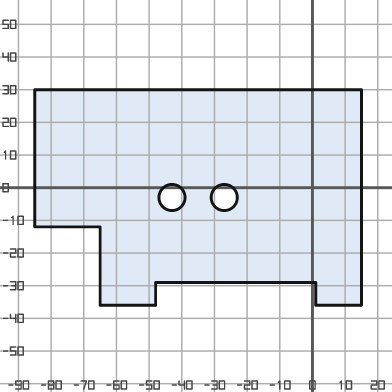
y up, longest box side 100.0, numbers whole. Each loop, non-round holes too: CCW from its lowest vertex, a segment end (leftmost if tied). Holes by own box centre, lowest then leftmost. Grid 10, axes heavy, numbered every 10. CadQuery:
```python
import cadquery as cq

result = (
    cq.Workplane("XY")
    .moveTo(-65.0, -36.0)
    .lineTo(-48.0, -36.0)
    .lineTo(-48.0, -29.0)
    .lineTo(1.0, -29.0)
    .lineTo(1.0, -36.0)
    .lineTo(15.0, -36.0)
    .lineTo(15.0, 30.0)
    .lineTo(-85.0, 30.0)
    .lineTo(-85.0, -12.0)
    .lineTo(-65.0, -12.0)
    .close()
    .moveTo(-43.0, -3.0)
    .circle(4.0)
    .moveTo(-27.0, -3.0)
    .circle(4.0)
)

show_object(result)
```